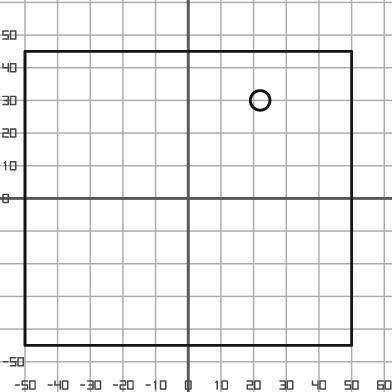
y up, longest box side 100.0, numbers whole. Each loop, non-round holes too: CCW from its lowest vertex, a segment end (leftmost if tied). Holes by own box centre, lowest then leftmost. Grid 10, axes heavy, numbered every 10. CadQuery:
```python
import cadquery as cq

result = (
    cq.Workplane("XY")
    .moveTo(-50.0, -45.0)
    .lineTo(50.0, -45.0)
    .lineTo(50.0, 45.0)
    .lineTo(-50.0, 45.0)
    .close()
    .moveTo(22.0, 30.0)
    .circle(3.0)
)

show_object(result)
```